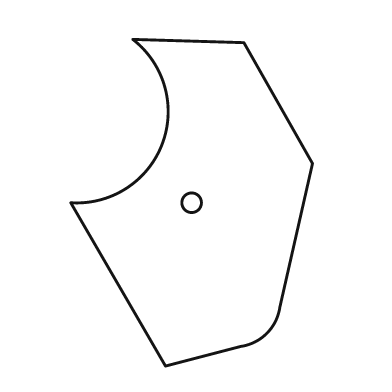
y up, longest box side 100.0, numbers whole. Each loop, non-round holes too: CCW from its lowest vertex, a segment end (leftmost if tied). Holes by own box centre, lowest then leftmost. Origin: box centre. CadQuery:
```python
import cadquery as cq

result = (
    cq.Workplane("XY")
    .moveTo(-8.0, -50.0)
    .lineTo(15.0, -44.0)
    .threePointArc((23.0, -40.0), (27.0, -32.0))
    .lineTo(37.0, 12.0)
    .lineTo(16.0, 49.0)
    .lineTo(-18.0, 50.0)
    .threePointArc((-9.0, 18.0), (-37.0, 0.0))
    .close()
    .moveTo(0.0, 0.0)
    .circle(3.0)
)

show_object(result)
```